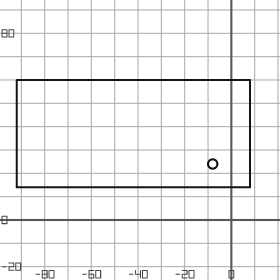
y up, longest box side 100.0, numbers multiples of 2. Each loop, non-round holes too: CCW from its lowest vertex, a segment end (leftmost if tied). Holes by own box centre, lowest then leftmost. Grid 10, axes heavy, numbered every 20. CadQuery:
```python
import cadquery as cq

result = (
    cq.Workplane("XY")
    .moveTo(-92.0, 14.0)
    .lineTo(8.0, 14.0)
    .lineTo(8.0, 60.0)
    .lineTo(-92.0, 60.0)
    .close()
    .moveTo(-8.0, 24.0)
    .circle(2.0)
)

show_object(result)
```